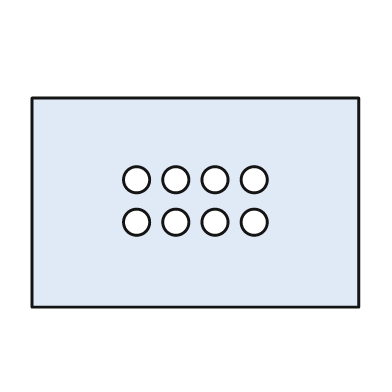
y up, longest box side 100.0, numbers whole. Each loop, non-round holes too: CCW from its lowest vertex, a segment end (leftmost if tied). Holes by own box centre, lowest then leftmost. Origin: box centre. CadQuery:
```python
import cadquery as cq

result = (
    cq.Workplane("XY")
    .moveTo(-50.0, -32.0)
    .lineTo(50.0, -32.0)
    .lineTo(50.0, 32.0)
    .lineTo(-50.0, 32.0)
    .close()
    .moveTo(-18.0, -6.0)
    .circle(4.0)
    .moveTo(-6.0, -6.0)
    .circle(4.0)
    .moveTo(6.0, -6.0)
    .circle(4.0)
    .moveTo(18.0, -6.0)
    .circle(4.0)
    .moveTo(-18.0, 7.0)
    .circle(4.0)
    .moveTo(-6.0, 7.0)
    .circle(4.0)
    .moveTo(6.0, 7.0)
    .circle(4.0)
    .moveTo(18.0, 7.0)
    .circle(4.0)
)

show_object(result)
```